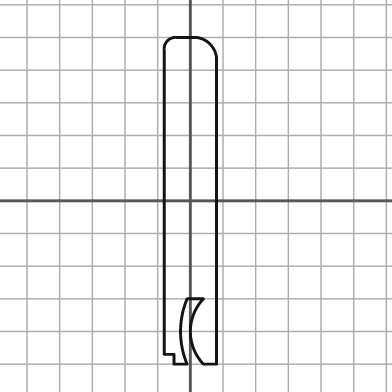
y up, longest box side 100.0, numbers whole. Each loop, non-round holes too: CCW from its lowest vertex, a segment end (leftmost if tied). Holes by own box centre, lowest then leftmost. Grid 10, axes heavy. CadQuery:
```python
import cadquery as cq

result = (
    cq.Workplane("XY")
    .moveTo(-5.0, -50.0)
    .lineTo(-1.0, -50.0)
    .threePointArc((-3.0, -40.0), (-1.0, -30.0))
    .lineTo(4.0, -30.0)
    .threePointArc((0.0, -40.0), (4.0, -50.0))
    .lineTo(8.0, -50.0)
    .lineTo(8.0, 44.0)
    .threePointArc((6.0, 48.0), (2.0, 50.0))
    .lineTo(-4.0, 50.0)
    .threePointArc((-7.0, 49.0), (-8.0, 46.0))
    .lineTo(-8.0, -47.0)
    .lineTo(-5.0, -47.0)
    .close()
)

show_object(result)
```